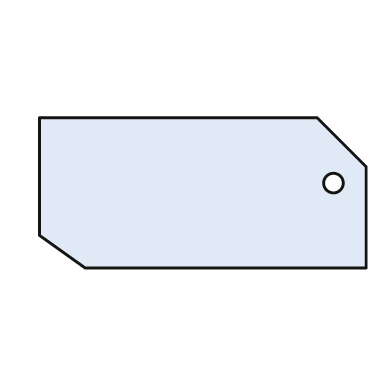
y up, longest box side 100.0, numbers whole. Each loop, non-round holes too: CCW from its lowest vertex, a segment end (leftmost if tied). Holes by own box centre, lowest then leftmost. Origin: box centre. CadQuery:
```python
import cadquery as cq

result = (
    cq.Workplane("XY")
    .moveTo(-36.0, -23.0)
    .lineTo(50.0, -23.0)
    .lineTo(50.0, 8.0)
    .lineTo(35.0, 23.0)
    .lineTo(-50.0, 23.0)
    .lineTo(-50.0, -13.0)
    .close()
    .moveTo(40.0, 3.0)
    .circle(3.0)
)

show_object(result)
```